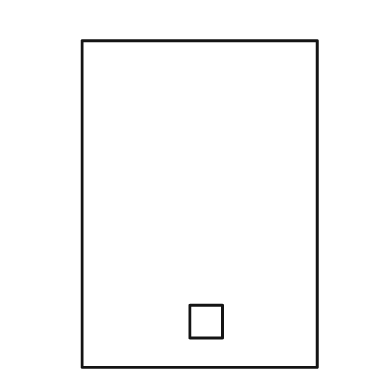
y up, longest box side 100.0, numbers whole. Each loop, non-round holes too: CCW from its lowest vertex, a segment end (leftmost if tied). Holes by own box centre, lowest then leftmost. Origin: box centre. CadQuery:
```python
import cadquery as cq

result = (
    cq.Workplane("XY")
    .moveTo(-36.0, -50.0)
    .lineTo(36.0, -50.0)
    .lineTo(36.0, 50.0)
    .lineTo(-36.0, 50.0)
    .close()
    .moveTo(-3.0, -41.0)
    .lineTo(7.0, -41.0)
    .lineTo(7.0, -31.0)
    .lineTo(-3.0, -31.0)
    .close()
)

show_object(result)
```